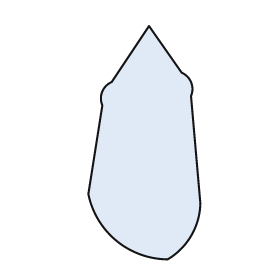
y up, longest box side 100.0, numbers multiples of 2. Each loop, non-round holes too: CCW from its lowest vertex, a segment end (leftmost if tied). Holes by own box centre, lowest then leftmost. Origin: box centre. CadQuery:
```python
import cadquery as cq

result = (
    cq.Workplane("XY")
    .moveTo(10.0, -50.0)
    .threePointArc((20.0, -40.0), (24.0, -26.0))
    .lineTo(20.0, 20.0)
    .threePointArc((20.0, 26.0), (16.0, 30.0))
    .lineTo(2.0, 50.0)
    .lineTo(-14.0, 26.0)
    .threePointArc((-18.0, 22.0), (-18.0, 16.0))
    .lineTo(-24.0, -22.0)
    .threePointArc((-12.0, -42.0), (10.0, -50.0))
    .close()
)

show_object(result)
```